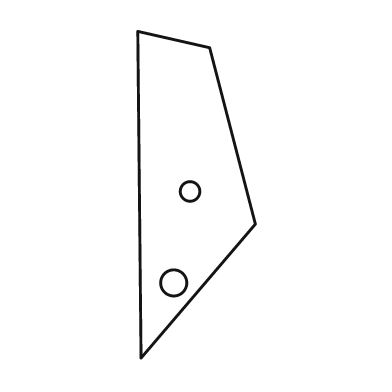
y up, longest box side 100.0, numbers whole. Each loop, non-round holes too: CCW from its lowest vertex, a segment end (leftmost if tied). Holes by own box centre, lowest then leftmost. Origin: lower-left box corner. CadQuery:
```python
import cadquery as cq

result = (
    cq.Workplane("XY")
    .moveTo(1.0, 0.0)
    .lineTo(36.0, 41.0)
    .lineTo(22.0, 95.0)
    .lineTo(0.0, 100.0)
    .close()
    .moveTo(11.0, 23.0)
    .circle(4.0)
    .moveTo(16.0, 51.0)
    .circle(3.0)
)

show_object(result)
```